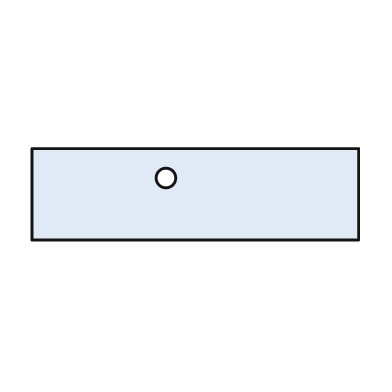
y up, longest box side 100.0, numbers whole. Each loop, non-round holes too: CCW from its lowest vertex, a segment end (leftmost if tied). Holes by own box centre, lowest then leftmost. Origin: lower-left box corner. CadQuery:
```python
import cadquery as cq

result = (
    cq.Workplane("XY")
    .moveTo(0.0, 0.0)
    .lineTo(100.0, 0.0)
    .lineTo(100.0, 28.0)
    .lineTo(0.0, 28.0)
    .close()
    .moveTo(41.0, 19.0)
    .circle(3.0)
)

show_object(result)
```